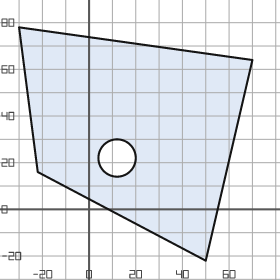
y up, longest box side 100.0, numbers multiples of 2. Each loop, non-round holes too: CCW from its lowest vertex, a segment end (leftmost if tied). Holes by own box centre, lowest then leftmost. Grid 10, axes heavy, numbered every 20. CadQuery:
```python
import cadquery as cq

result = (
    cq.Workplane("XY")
    .moveTo(50.0, -22.0)
    .lineTo(70.0, 64.0)
    .lineTo(-30.0, 78.0)
    .lineTo(-22.0, 16.0)
    .close()
    .moveTo(12.0, 22.0)
    .circle(8.0)
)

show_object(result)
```